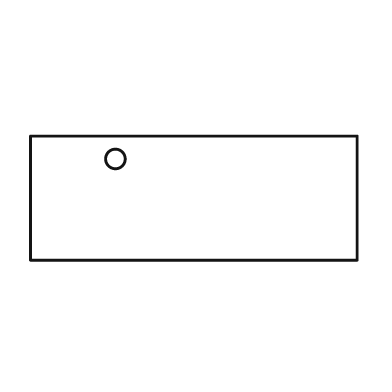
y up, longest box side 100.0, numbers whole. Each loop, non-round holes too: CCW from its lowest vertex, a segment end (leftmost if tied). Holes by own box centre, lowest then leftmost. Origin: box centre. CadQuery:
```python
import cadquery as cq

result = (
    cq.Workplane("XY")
    .moveTo(-50.0, -19.0)
    .lineTo(50.0, -19.0)
    .lineTo(50.0, 19.0)
    .lineTo(-50.0, 19.0)
    .close()
    .moveTo(-24.0, 12.0)
    .circle(3.0)
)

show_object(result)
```